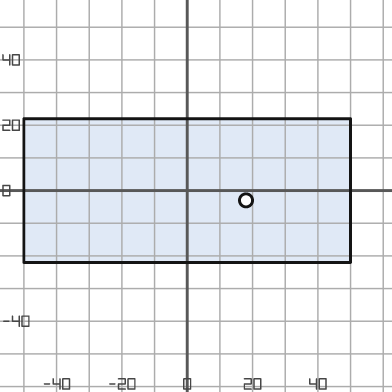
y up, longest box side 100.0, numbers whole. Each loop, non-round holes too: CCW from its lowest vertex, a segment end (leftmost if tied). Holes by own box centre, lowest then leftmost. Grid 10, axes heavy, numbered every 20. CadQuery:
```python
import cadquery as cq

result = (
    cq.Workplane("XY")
    .moveTo(-50.0, -22.0)
    .lineTo(50.0, -22.0)
    .lineTo(50.0, 22.0)
    .lineTo(-50.0, 22.0)
    .close()
    .moveTo(18.0, -3.0)
    .circle(2.0)
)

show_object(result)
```